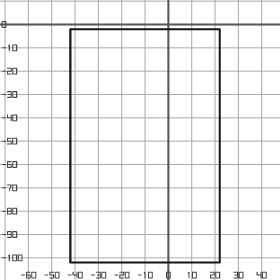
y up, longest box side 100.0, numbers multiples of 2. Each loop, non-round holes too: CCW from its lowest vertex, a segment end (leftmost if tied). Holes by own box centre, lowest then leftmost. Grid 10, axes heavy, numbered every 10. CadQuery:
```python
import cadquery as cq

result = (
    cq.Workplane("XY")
    .moveTo(-42.0, -102.0)
    .lineTo(22.0, -102.0)
    .lineTo(22.0, -2.0)
    .lineTo(-42.0, -2.0)
    .close()
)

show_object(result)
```